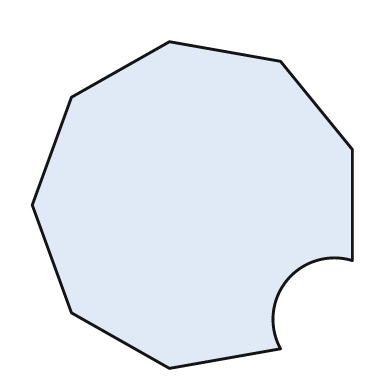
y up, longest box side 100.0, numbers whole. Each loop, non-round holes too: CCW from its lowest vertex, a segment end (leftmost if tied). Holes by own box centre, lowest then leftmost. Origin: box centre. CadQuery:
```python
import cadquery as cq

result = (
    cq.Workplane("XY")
    .moveTo(-7.0, -50.0)
    .lineTo(27.0, -44.0)
    .threePointArc((29.0, -23.0), (49.0, -17.0))
    .lineTo(49.0, 17.0)
    .lineTo(27.0, 44.0)
    .lineTo(-7.0, 50.0)
    .lineTo(-37.0, 33.0)
    .lineTo(-49.0, 0.0)
    .lineTo(-37.0, -33.0)
    .close()
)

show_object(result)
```